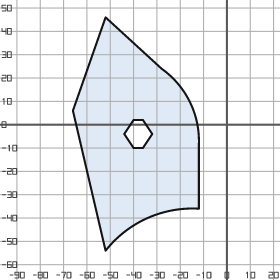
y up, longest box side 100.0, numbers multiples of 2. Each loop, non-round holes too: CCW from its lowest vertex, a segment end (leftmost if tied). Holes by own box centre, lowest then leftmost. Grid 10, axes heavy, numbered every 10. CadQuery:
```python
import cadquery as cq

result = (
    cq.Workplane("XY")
    .moveTo(-52.0, -54.0)
    .threePointArc((-34.0, -40.0), (-12.0, -36.0))
    .lineTo(-12.0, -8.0)
    .threePointArc((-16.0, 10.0), (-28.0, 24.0))
    .lineTo(-52.0, 46.0)
    .lineTo(-66.0, 6.0)
    .close()
    .moveTo(-40.0, -10.0)
    .lineTo(-36.0, -10.0)
    .lineTo(-32.0, -4.0)
    .lineTo(-36.0, 2.0)
    .lineTo(-40.0, 2.0)
    .lineTo(-44.0, -4.0)
    .close()
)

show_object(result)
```